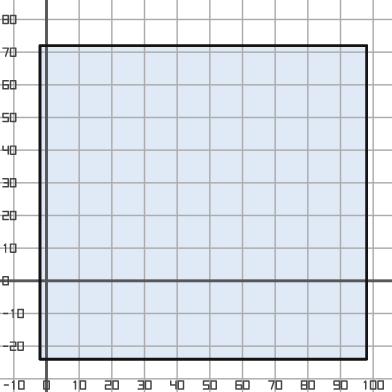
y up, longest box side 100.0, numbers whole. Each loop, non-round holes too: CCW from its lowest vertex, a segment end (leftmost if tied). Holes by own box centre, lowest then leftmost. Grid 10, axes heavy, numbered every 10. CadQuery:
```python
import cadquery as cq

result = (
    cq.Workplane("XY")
    .moveTo(-2.0, -24.0)
    .lineTo(98.0, -24.0)
    .lineTo(98.0, 72.0)
    .lineTo(-2.0, 72.0)
    .close()
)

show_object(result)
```